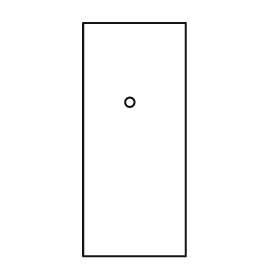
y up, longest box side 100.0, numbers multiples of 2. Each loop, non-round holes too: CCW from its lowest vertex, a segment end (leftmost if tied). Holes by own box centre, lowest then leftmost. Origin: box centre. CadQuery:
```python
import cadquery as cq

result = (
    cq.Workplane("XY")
    .moveTo(-22.0, -50.0)
    .lineTo(22.0, -50.0)
    .lineTo(22.0, 50.0)
    .lineTo(-22.0, 50.0)
    .close()
    .moveTo(-2.0, 16.0)
    .circle(2.0)
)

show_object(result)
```